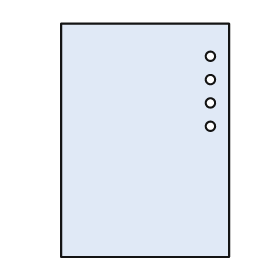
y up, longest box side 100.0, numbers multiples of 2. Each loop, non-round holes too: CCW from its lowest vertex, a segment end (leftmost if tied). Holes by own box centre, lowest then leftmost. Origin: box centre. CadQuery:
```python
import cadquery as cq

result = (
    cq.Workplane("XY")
    .moveTo(-36.0, -50.0)
    .lineTo(36.0, -50.0)
    .lineTo(36.0, 50.0)
    .lineTo(-36.0, 50.0)
    .close()
    .moveTo(28.0, 6.0)
    .circle(2.0)
    .moveTo(28.0, 16.0)
    .circle(2.0)
    .moveTo(28.0, 26.0)
    .circle(2.0)
    .moveTo(28.0, 36.0)
    .circle(2.0)
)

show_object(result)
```